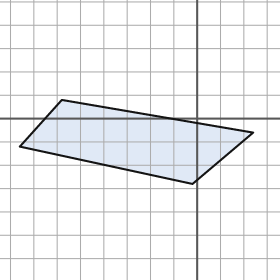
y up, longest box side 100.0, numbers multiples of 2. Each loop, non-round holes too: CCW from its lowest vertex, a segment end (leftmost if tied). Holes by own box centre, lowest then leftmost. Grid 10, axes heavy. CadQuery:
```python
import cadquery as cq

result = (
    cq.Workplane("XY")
    .moveTo(-2.0, -28.0)
    .lineTo(24.0, -6.0)
    .lineTo(-58.0, 8.0)
    .lineTo(-76.0, -12.0)
    .close()
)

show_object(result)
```